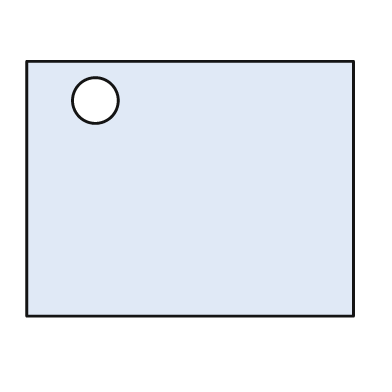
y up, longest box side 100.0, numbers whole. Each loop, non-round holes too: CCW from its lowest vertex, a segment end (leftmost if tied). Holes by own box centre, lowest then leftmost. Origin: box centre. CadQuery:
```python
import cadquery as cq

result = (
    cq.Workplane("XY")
    .moveTo(-50.0, -39.0)
    .lineTo(50.0, -39.0)
    .lineTo(50.0, 39.0)
    .lineTo(-50.0, 39.0)
    .close()
    .moveTo(-29.0, 27.0)
    .circle(7.0)
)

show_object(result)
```